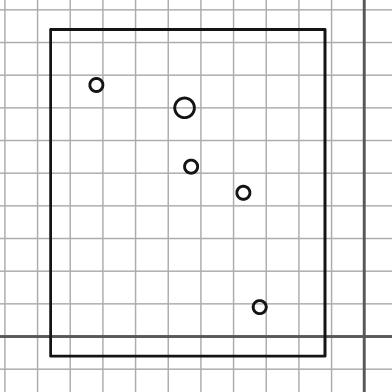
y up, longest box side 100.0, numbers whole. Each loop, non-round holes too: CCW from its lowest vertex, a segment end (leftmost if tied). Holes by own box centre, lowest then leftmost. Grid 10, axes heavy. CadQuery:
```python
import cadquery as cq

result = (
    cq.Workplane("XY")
    .moveTo(-96.0, -6.0)
    .lineTo(-12.0, -6.0)
    .lineTo(-12.0, 94.0)
    .lineTo(-96.0, 94.0)
    .close()
    .moveTo(-32.0, 9.0)
    .circle(2.0)
    .moveTo(-37.0, 44.0)
    .circle(2.0)
    .moveTo(-53.0, 52.0)
    .circle(2.0)
    .moveTo(-55.0, 70.0)
    .circle(3.0)
    .moveTo(-82.0, 77.0)
    .circle(2.0)
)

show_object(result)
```